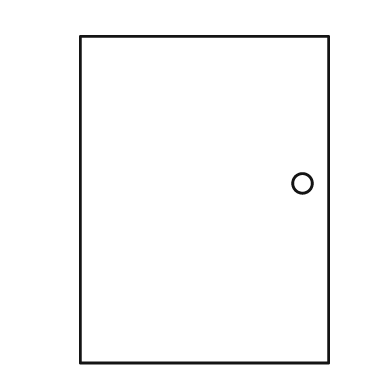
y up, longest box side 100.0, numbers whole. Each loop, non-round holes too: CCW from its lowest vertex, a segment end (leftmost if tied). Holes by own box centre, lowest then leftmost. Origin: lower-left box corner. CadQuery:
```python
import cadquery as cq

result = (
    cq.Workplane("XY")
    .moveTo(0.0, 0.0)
    .lineTo(76.0, 0.0)
    .lineTo(76.0, 100.0)
    .lineTo(0.0, 100.0)
    .close()
    .moveTo(68.0, 55.0)
    .circle(3.0)
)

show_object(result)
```